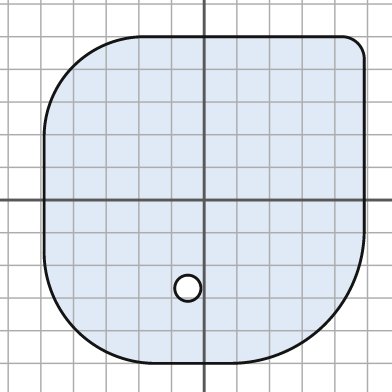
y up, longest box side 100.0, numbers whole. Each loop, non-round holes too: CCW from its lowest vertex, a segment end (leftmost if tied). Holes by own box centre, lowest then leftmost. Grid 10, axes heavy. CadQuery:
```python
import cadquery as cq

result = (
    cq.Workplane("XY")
    .moveTo(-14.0, -50.0)
    .lineTo(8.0, -50.0)
    .threePointArc((37.0, -38.0), (49.0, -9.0))
    .lineTo(49.0, 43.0)
    .threePointArc((47.0, 48.0), (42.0, 50.0))
    .lineTo(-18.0, 50.0)
    .threePointArc((-40.0, 41.0), (-49.0, 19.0))
    .lineTo(-49.0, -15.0)
    .threePointArc((-39.0, -40.0), (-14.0, -50.0))
    .close()
    .moveTo(-5.0, -27.0)
    .circle(4.0)
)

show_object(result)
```